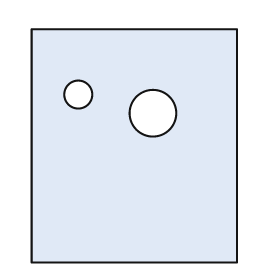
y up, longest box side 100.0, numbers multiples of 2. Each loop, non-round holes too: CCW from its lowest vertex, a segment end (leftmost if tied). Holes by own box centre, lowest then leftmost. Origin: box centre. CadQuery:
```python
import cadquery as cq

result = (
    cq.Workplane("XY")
    .moveTo(-44.0, -50.0)
    .lineTo(44.0, -50.0)
    .lineTo(44.0, 50.0)
    .lineTo(-44.0, 50.0)
    .close()
    .moveTo(8.0, 14.0)
    .circle(10.0)
    .moveTo(-24.0, 22.0)
    .circle(6.0)
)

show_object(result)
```